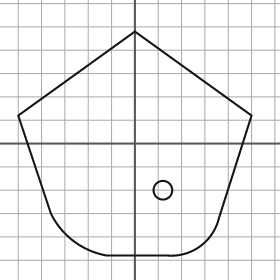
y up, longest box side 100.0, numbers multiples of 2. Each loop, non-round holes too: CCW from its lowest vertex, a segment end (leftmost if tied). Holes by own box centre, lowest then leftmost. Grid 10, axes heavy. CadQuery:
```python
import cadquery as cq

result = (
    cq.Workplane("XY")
    .moveTo(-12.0, -48.0)
    .lineTo(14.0, -48.0)
    .threePointArc((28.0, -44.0), (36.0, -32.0))
    .lineTo(50.0, 12.0)
    .lineTo(0.0, 48.0)
    .lineTo(-50.0, 12.0)
    .lineTo(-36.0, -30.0)
    .threePointArc((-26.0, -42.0), (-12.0, -48.0))
    .close()
    .moveTo(12.0, -20.0)
    .circle(4.0)
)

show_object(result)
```